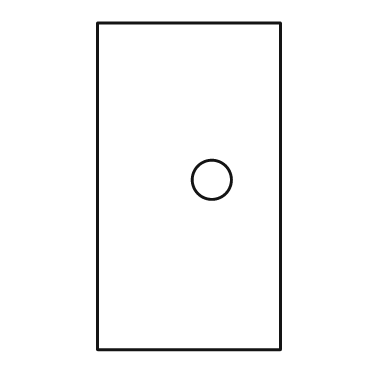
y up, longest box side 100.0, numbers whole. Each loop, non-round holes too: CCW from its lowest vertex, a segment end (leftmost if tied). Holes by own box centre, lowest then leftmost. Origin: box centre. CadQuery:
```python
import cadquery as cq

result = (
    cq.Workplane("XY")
    .moveTo(-28.0, -50.0)
    .lineTo(28.0, -50.0)
    .lineTo(28.0, 50.0)
    .lineTo(-28.0, 50.0)
    .close()
    .moveTo(7.0, 2.0)
    .circle(6.0)
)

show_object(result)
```